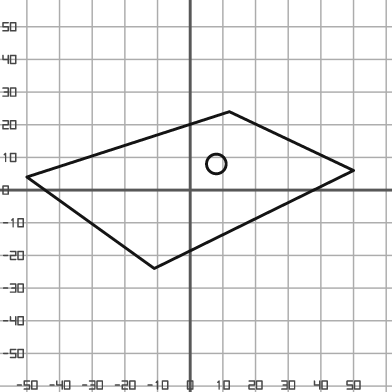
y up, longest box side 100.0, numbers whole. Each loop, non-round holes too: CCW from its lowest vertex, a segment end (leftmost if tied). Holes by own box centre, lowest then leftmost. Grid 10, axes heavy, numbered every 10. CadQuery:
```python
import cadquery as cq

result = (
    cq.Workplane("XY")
    .moveTo(-11.0, -24.0)
    .lineTo(50.0, 6.0)
    .lineTo(12.0, 24.0)
    .lineTo(-50.0, 4.0)
    .close()
    .moveTo(8.0, 8.0)
    .circle(3.0)
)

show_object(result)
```